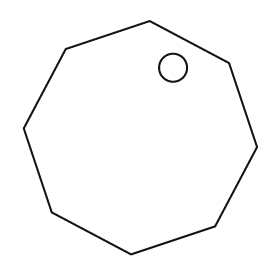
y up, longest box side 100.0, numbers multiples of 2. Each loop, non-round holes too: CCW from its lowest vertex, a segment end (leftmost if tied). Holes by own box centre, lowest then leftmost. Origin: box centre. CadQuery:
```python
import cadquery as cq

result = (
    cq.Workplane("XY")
    .moveTo(-4.0, -50.0)
    .lineTo(32.0, -38.0)
    .lineTo(50.0, -4.0)
    .lineTo(38.0, 32.0)
    .lineTo(4.0, 50.0)
    .lineTo(-32.0, 38.0)
    .lineTo(-50.0, 4.0)
    .lineTo(-38.0, -32.0)
    .close()
    .moveTo(14.0, 30.0)
    .circle(6.0)
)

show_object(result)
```